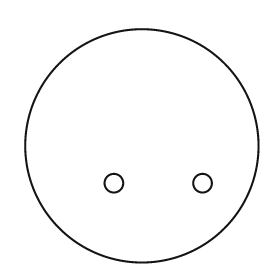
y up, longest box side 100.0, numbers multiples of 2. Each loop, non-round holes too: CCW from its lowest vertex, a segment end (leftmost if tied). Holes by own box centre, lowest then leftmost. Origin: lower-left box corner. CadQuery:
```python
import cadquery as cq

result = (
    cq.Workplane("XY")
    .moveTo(50.0, 50.0)
    .circle(50.0)
    .moveTo(38.0, 34.0)
    .circle(4.0)
    .moveTo(76.0, 34.0)
    .circle(4.0)
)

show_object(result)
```